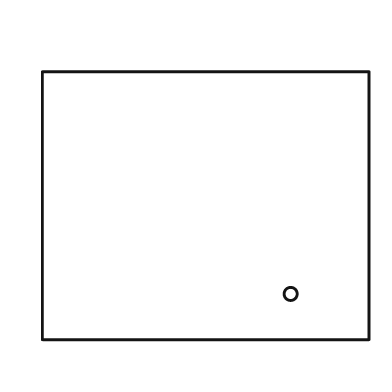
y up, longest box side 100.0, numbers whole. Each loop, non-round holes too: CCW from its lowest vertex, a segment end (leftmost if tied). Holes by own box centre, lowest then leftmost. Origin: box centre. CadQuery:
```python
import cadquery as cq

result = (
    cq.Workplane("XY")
    .moveTo(-50.0, -41.0)
    .lineTo(50.0, -41.0)
    .lineTo(50.0, 41.0)
    .lineTo(-50.0, 41.0)
    .close()
    .moveTo(26.0, -27.0)
    .circle(2.0)
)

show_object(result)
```